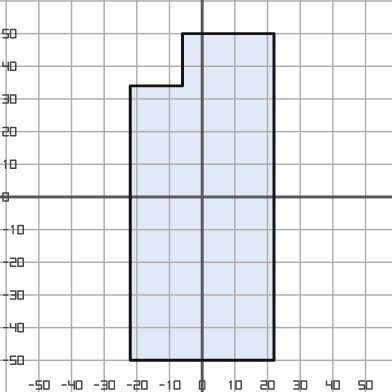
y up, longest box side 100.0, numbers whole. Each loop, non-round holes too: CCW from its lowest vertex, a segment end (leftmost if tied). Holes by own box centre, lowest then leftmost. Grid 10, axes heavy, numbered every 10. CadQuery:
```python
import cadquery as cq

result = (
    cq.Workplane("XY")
    .moveTo(-22.0, -50.0)
    .lineTo(22.0, -50.0)
    .lineTo(22.0, 50.0)
    .lineTo(-6.0, 50.0)
    .lineTo(-6.0, 34.0)
    .lineTo(-22.0, 34.0)
    .close()
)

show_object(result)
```